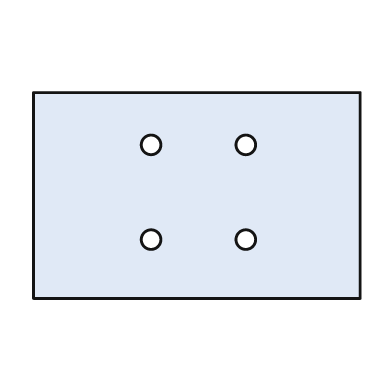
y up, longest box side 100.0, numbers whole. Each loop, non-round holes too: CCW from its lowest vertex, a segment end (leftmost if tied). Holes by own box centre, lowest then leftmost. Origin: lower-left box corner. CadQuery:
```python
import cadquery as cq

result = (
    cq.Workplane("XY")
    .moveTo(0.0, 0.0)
    .lineTo(100.0, 0.0)
    .lineTo(100.0, 63.0)
    .lineTo(0.0, 63.0)
    .close()
    .moveTo(36.0, 18.0)
    .circle(3.0)
    .moveTo(65.0, 18.0)
    .circle(3.0)
    .moveTo(36.0, 47.0)
    .circle(3.0)
    .moveTo(65.0, 47.0)
    .circle(3.0)
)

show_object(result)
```